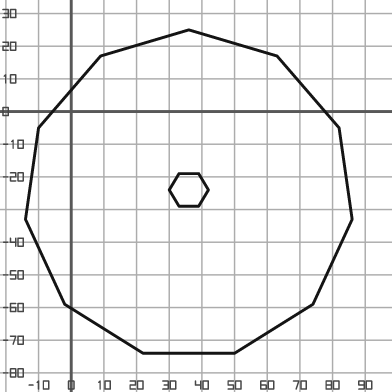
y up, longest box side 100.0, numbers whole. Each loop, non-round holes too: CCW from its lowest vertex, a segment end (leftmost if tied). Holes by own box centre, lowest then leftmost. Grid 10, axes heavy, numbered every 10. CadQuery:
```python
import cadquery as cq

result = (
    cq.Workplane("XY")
    .moveTo(22.0, -74.0)
    .lineTo(50.0, -74.0)
    .lineTo(74.0, -59.0)
    .lineTo(86.0, -33.0)
    .lineTo(82.0, -5.0)
    .lineTo(63.0, 17.0)
    .lineTo(36.0, 25.0)
    .lineTo(9.0, 17.0)
    .lineTo(-10.0, -5.0)
    .lineTo(-14.0, -33.0)
    .lineTo(-2.0, -59.0)
    .close()
    .moveTo(33.0, -29.0)
    .lineTo(39.0, -29.0)
    .lineTo(42.0, -24.0)
    .lineTo(39.0, -19.0)
    .lineTo(33.0, -19.0)
    .lineTo(30.0, -24.0)
    .close()
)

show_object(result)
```